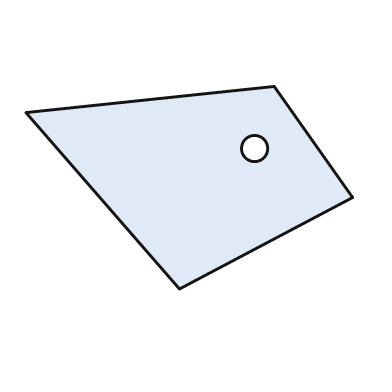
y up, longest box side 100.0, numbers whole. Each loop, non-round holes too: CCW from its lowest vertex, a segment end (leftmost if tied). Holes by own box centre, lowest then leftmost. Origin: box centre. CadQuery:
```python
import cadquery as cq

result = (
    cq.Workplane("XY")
    .moveTo(-3.0, -31.0)
    .lineTo(50.0, -3.0)
    .lineTo(26.0, 31.0)
    .lineTo(-50.0, 23.0)
    .close()
    .moveTo(20.0, 12.0)
    .circle(4.0)
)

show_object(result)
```